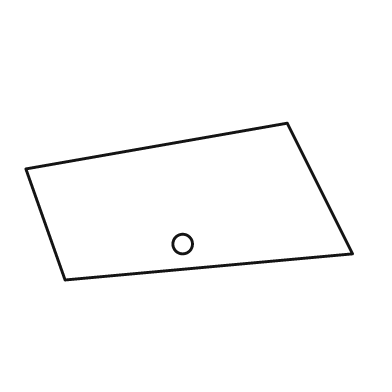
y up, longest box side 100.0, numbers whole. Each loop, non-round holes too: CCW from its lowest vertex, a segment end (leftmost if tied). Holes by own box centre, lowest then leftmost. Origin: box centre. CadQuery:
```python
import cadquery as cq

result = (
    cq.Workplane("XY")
    .moveTo(-38.0, -24.0)
    .lineTo(50.0, -16.0)
    .lineTo(30.0, 24.0)
    .lineTo(-50.0, 10.0)
    .close()
    .moveTo(-2.0, -13.0)
    .circle(3.0)
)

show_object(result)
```